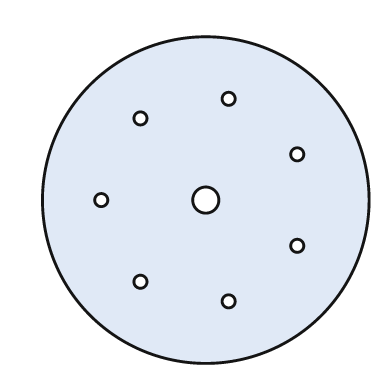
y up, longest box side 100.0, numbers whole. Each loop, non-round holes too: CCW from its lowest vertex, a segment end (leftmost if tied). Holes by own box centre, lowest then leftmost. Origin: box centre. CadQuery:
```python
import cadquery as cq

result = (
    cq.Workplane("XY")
    .moveTo(0.0, 0.0)
    .circle(50.0)
    .moveTo(7.0, -31.0)
    .circle(2.0)
    .moveTo(-20.0, -25.0)
    .circle(2.0)
    .moveTo(28.0, -14.0)
    .circle(2.0)
    .moveTo(-32.0, 0.0)
    .circle(2.0)
    .moveTo(0.0, 0.0)
    .circle(4.0)
    .moveTo(28.0, 14.0)
    .circle(2.0)
    .moveTo(-20.0, 25.0)
    .circle(2.0)
    .moveTo(7.0, 31.0)
    .circle(2.0)
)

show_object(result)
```